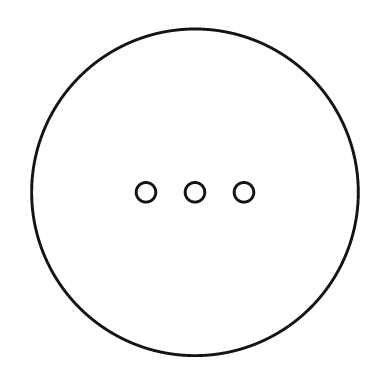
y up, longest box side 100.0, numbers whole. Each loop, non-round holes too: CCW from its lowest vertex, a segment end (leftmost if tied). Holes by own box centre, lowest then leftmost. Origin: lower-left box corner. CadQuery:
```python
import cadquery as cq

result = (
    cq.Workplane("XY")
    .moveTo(50.0, 50.0)
    .circle(50.0)
    .moveTo(35.0, 50.0)
    .circle(3.0)
    .moveTo(50.0, 50.0)
    .circle(3.0)
    .moveTo(65.0, 50.0)
    .circle(3.0)
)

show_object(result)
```